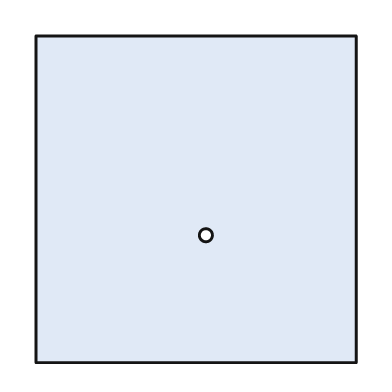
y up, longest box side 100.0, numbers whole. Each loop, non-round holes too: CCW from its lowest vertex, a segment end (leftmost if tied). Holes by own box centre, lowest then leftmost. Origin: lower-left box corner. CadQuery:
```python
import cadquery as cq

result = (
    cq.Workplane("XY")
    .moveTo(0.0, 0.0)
    .lineTo(98.0, 0.0)
    .lineTo(98.0, 100.0)
    .lineTo(0.0, 100.0)
    .close()
    .moveTo(52.0, 39.0)
    .circle(2.0)
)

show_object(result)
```